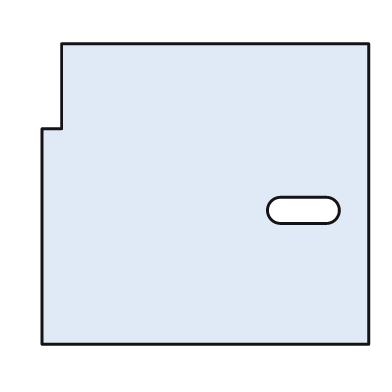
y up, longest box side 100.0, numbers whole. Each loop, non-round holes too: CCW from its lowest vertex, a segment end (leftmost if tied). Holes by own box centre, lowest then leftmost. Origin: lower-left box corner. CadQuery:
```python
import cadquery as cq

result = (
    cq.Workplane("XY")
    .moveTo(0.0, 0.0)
    .lineTo(100.0, 0.0)
    .lineTo(100.0, 92.0)
    .lineTo(6.0, 92.0)
    .lineTo(6.0, 66.0)
    .lineTo(0.0, 66.0)
    .close()
    .moveTo(73.0, 37.0)
    .lineTo(87.0, 37.0)
    .threePointArc((91.0, 41.0), (87.0, 45.0))
    .lineTo(73.0, 45.0)
    .threePointArc((69.0, 41.0), (73.0, 37.0))
    .close()
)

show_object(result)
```